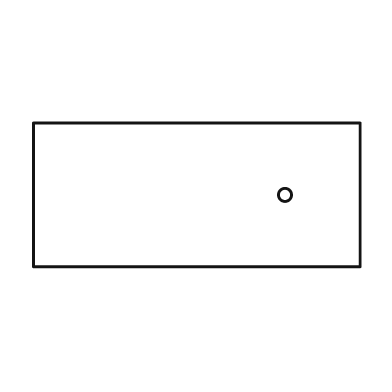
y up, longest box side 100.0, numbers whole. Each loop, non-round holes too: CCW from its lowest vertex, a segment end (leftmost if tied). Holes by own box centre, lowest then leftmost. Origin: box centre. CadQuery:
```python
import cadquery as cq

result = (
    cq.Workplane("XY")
    .moveTo(-50.0, -22.0)
    .lineTo(50.0, -22.0)
    .lineTo(50.0, 22.0)
    .lineTo(-50.0, 22.0)
    .close()
    .moveTo(27.0, 0.0)
    .circle(2.0)
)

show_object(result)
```